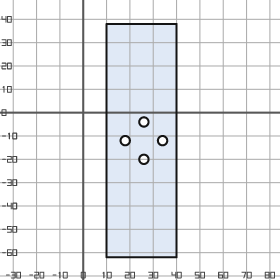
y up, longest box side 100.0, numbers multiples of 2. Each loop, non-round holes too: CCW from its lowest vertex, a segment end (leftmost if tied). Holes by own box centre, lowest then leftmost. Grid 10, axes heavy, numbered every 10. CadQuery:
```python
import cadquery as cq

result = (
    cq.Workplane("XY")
    .moveTo(10.0, -62.0)
    .lineTo(40.0, -62.0)
    .lineTo(40.0, 38.0)
    .lineTo(10.0, 38.0)
    .close()
    .moveTo(26.0, -20.0)
    .circle(2.0)
    .moveTo(18.0, -12.0)
    .circle(2.0)
    .moveTo(34.0, -12.0)
    .circle(2.0)
    .moveTo(26.0, -4.0)
    .circle(2.0)
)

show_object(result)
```